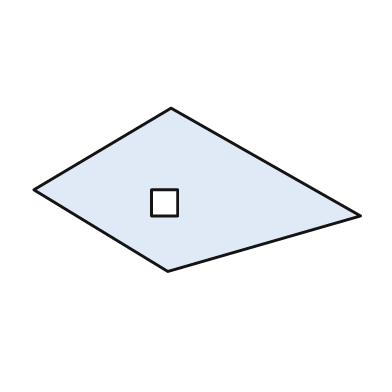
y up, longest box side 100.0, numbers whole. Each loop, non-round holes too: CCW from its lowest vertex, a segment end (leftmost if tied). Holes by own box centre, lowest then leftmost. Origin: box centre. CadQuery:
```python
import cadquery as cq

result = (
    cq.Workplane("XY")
    .moveTo(-9.0, -25.0)
    .lineTo(50.0, -8.0)
    .lineTo(-8.0, 25.0)
    .lineTo(-50.0, 0.0)
    .close()
    .moveTo(-14.0, -8.0)
    .lineTo(-6.0, -8.0)
    .lineTo(-6.0, 0.0)
    .lineTo(-14.0, 0.0)
    .close()
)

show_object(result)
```